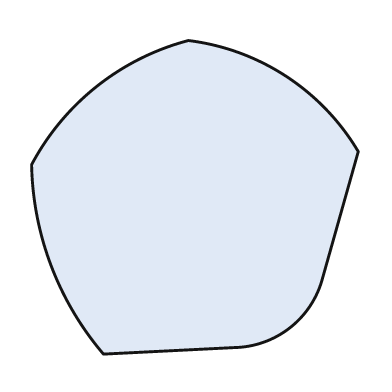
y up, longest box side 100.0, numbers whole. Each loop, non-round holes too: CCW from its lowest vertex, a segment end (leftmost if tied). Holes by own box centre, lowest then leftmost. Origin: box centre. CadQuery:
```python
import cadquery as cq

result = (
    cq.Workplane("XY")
    .moveTo(-28.0, -48.0)
    .lineTo(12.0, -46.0)
    .threePointArc((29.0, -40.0), (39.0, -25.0))
    .lineTo(50.0, 14.0)
    .threePointArc((28.0, 37.0), (-2.0, 48.0))
    .threePointArc((-30.0, 34.0), (-50.0, 10.0))
    .threePointArc((-44.0, -21.0), (-28.0, -48.0))
    .close()
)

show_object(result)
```